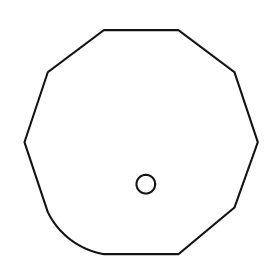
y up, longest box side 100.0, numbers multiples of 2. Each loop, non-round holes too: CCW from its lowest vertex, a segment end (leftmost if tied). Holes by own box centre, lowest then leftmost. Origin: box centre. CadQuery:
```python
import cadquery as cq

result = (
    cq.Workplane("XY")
    .moveTo(-16.0, -48.0)
    .lineTo(16.0, -48.0)
    .lineTo(40.0, -28.0)
    .lineTo(50.0, 0.0)
    .lineTo(40.0, 30.0)
    .lineTo(16.0, 48.0)
    .lineTo(-16.0, 48.0)
    .lineTo(-40.0, 30.0)
    .lineTo(-50.0, 0.0)
    .lineTo(-40.0, -30.0)
    .threePointArc((-30.0, -42.0), (-16.0, -48.0))
    .close()
    .moveTo(2.0, -18.0)
    .circle(4.0)
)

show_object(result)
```